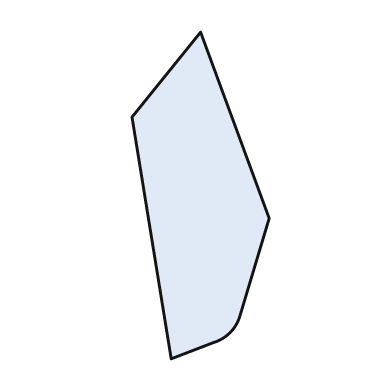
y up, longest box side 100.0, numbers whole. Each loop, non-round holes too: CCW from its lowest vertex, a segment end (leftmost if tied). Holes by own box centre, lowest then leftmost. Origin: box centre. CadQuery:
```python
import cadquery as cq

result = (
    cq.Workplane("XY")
    .moveTo(-9.0, -50.0)
    .lineTo(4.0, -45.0)
    .threePointArc((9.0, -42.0), (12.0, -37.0))
    .lineTo(21.0, -7.0)
    .lineTo(0.0, 50.0)
    .lineTo(-21.0, 24.0)
    .close()
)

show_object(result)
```